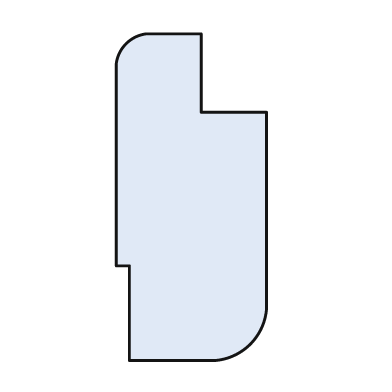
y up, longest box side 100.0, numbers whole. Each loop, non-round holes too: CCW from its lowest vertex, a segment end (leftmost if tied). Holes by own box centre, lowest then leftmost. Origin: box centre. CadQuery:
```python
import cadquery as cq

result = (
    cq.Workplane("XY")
    .moveTo(-19.0, -50.0)
    .lineTo(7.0, -50.0)
    .threePointArc((18.0, -45.0), (23.0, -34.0))
    .lineTo(23.0, 26.0)
    .lineTo(3.0, 26.0)
    .lineTo(3.0, 50.0)
    .lineTo(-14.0, 50.0)
    .threePointArc((-20.0, 47.0), (-23.0, 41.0))
    .lineTo(-23.0, -21.0)
    .lineTo(-19.0, -21.0)
    .close()
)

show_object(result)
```